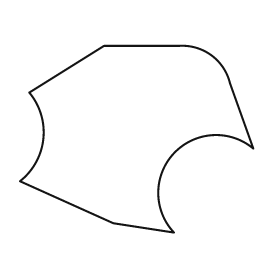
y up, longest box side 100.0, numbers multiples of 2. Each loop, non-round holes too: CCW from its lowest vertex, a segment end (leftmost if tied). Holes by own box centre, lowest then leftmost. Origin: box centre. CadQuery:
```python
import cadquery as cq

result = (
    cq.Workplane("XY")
    .moveTo(16.0, -40.0)
    .threePointArc((16.0, -6.0), (50.0, -4.0))
    .lineTo(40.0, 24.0)
    .threePointArc((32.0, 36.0), (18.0, 40.0))
    .lineTo(-14.0, 40.0)
    .lineTo(-46.0, 20.0)
    .threePointArc((-40.0, 0.0), (-50.0, -18.0))
    .lineTo(-10.0, -36.0)
    .close()
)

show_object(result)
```